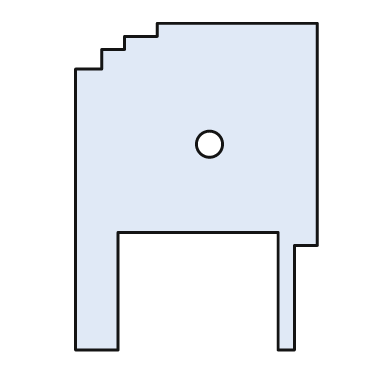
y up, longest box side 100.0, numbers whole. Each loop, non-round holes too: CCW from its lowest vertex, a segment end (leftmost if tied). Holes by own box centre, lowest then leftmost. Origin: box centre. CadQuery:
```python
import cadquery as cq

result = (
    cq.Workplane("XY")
    .moveTo(-37.0, -50.0)
    .lineTo(-24.0, -50.0)
    .lineTo(-24.0, -14.0)
    .lineTo(25.0, -14.0)
    .lineTo(25.0, -50.0)
    .lineTo(30.0, -50.0)
    .lineTo(30.0, -18.0)
    .lineTo(37.0, -18.0)
    .lineTo(37.0, 50.0)
    .lineTo(-12.0, 50.0)
    .lineTo(-12.0, 46.0)
    .lineTo(-22.0, 46.0)
    .lineTo(-22.0, 42.0)
    .lineTo(-29.0, 42.0)
    .lineTo(-29.0, 36.0)
    .lineTo(-37.0, 36.0)
    .close()
    .moveTo(4.0, 13.0)
    .circle(4.0)
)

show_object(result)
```